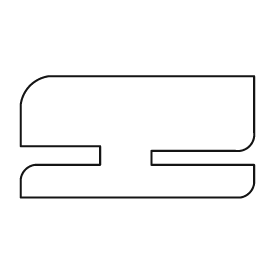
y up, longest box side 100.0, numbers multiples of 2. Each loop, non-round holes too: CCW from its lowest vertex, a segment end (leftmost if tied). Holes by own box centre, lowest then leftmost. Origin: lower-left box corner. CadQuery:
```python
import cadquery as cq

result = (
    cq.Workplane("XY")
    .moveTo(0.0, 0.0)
    .lineTo(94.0, 0.0)
    .threePointArc((98.0, 2.0), (100.0, 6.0))
    .lineTo(100.0, 14.0)
    .lineTo(56.0, 14.0)
    .lineTo(56.0, 20.0)
    .lineTo(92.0, 20.0)
    .threePointArc((98.0, 22.0), (100.0, 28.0))
    .lineTo(100.0, 52.0)
    .lineTo(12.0, 52.0)
    .threePointArc((4.0, 48.0), (0.0, 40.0))
    .lineTo(0.0, 22.0)
    .lineTo(34.0, 22.0)
    .lineTo(34.0, 14.0)
    .lineTo(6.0, 14.0)
    .threePointArc((2.0, 12.0), (0.0, 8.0))
    .close()
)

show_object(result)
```